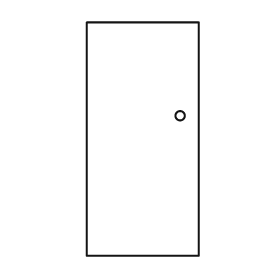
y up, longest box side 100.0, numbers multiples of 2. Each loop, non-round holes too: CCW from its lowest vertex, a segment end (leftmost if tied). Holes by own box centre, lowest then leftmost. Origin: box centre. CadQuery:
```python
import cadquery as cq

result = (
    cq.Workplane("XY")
    .moveTo(-24.0, -50.0)
    .lineTo(24.0, -50.0)
    .lineTo(24.0, 50.0)
    .lineTo(-24.0, 50.0)
    .close()
    .moveTo(16.0, 10.0)
    .circle(2.0)
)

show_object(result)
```